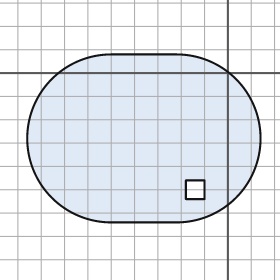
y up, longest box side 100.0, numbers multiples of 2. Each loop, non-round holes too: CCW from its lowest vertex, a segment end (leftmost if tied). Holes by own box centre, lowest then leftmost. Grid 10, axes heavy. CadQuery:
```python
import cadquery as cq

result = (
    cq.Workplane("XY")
    .moveTo(-50.0, -64.0)
    .lineTo(-22.0, -64.0)
    .threePointArc((14.0, -28.0), (-22.0, 8.0))
    .lineTo(-50.0, 8.0)
    .threePointArc((-86.0, -28.0), (-50.0, -64.0))
    .close()
    .moveTo(-18.0, -54.0)
    .lineTo(-10.0, -54.0)
    .lineTo(-10.0, -46.0)
    .lineTo(-18.0, -46.0)
    .close()
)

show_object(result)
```